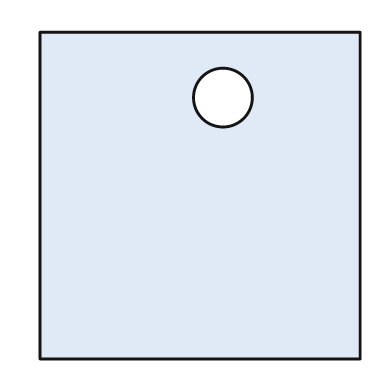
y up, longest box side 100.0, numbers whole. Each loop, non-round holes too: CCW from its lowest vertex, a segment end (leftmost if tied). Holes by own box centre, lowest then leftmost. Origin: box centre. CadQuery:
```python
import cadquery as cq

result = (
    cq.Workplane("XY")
    .moveTo(-49.0, -50.0)
    .lineTo(49.0, -50.0)
    .lineTo(49.0, 50.0)
    .lineTo(-49.0, 50.0)
    .close()
    .moveTo(7.0, 30.0)
    .circle(9.0)
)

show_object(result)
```